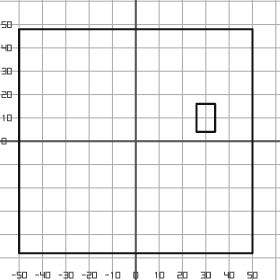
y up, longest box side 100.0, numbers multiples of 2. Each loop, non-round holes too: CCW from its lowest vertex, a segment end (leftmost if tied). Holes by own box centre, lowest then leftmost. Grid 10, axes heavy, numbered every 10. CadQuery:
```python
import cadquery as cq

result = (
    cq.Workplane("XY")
    .moveTo(-50.0, -48.0)
    .lineTo(50.0, -48.0)
    .lineTo(50.0, 48.0)
    .lineTo(-50.0, 48.0)
    .close()
    .moveTo(26.0, 4.0)
    .lineTo(34.0, 4.0)
    .lineTo(34.0, 16.0)
    .lineTo(26.0, 16.0)
    .close()
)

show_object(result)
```